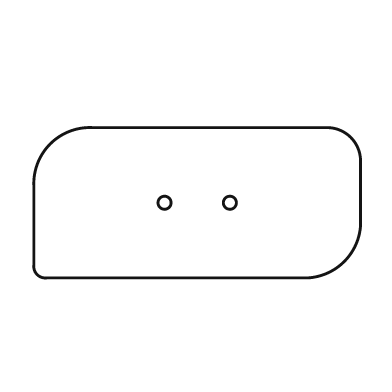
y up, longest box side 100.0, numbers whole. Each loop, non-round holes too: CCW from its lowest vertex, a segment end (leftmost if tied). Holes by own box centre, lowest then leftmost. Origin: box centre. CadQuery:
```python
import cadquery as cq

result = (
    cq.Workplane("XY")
    .moveTo(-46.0, -23.0)
    .lineTo(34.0, -23.0)
    .threePointArc((45.0, -18.0), (50.0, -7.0))
    .lineTo(50.0, 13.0)
    .threePointArc((47.0, 20.0), (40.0, 23.0))
    .lineTo(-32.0, 23.0)
    .threePointArc((-45.0, 18.0), (-50.0, 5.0))
    .lineTo(-50.0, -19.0)
    .threePointArc((-49.0, -22.0), (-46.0, -23.0))
    .close()
    .moveTo(-10.0, 0.0)
    .circle(2.0)
    .moveTo(10.0, 0.0)
    .circle(2.0)
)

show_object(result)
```